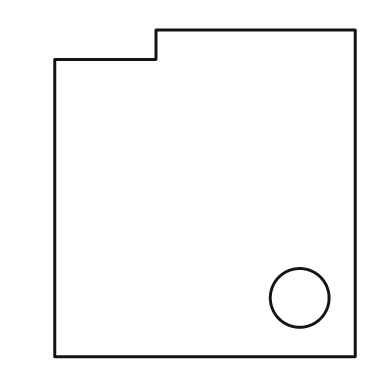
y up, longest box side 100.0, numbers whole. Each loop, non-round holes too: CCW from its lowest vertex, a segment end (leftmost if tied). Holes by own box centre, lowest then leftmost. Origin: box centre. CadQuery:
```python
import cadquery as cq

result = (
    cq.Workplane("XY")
    .moveTo(-46.0, -50.0)
    .lineTo(46.0, -50.0)
    .lineTo(46.0, 50.0)
    .lineTo(-15.0, 50.0)
    .lineTo(-15.0, 41.0)
    .lineTo(-46.0, 41.0)
    .close()
    .moveTo(29.0, -32.0)
    .circle(9.0)
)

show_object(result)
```